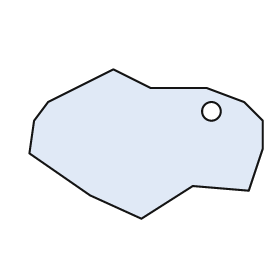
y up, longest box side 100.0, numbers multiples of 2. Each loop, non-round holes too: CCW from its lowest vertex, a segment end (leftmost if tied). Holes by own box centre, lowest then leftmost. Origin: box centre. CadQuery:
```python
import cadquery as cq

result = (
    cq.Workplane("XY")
    .moveTo(-2.0, -32.0)
    .lineTo(20.0, -18.0)
    .lineTo(44.0, -20.0)
    .lineTo(50.0, -2.0)
    .lineTo(50.0, 10.0)
    .lineTo(42.0, 18.0)
    .lineTo(26.0, 24.0)
    .lineTo(2.0, 24.0)
    .lineTo(-14.0, 32.0)
    .lineTo(-42.0, 18.0)
    .lineTo(-48.0, 10.0)
    .lineTo(-50.0, -4.0)
    .lineTo(-24.0, -22.0)
    .close()
    .moveTo(28.0, 14.0)
    .circle(4.0)
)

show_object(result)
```